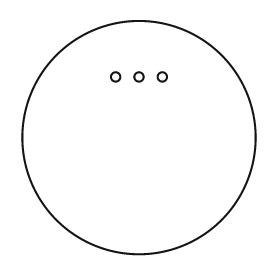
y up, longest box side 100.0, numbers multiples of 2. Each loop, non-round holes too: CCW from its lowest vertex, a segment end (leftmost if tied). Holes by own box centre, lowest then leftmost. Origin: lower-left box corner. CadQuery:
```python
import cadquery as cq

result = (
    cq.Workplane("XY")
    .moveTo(50.0, 50.0)
    .circle(50.0)
    .moveTo(40.0, 76.0)
    .circle(2.0)
    .moveTo(50.0, 76.0)
    .circle(2.0)
    .moveTo(60.0, 76.0)
    .circle(2.0)
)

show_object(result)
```